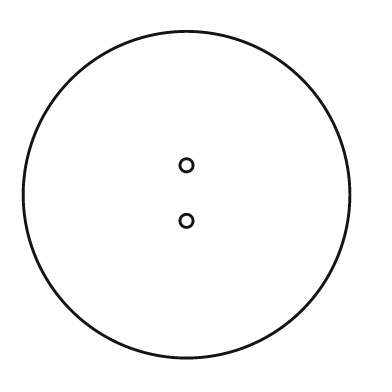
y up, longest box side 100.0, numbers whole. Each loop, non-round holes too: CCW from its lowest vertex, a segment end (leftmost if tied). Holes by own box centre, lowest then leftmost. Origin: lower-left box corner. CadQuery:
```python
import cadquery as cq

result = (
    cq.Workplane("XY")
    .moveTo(50.0, 50.0)
    .circle(50.0)
    .moveTo(50.0, 42.0)
    .circle(2.0)
    .moveTo(50.0, 59.0)
    .circle(2.0)
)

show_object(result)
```